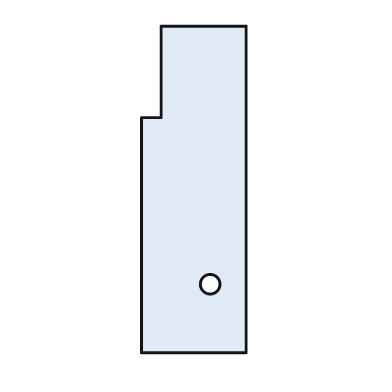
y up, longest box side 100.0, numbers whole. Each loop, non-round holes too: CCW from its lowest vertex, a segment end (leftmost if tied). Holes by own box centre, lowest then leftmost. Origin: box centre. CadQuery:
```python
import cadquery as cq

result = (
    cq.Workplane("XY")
    .moveTo(-16.0, -50.0)
    .lineTo(16.0, -50.0)
    .lineTo(16.0, 50.0)
    .lineTo(-10.0, 50.0)
    .lineTo(-10.0, 22.0)
    .lineTo(-16.0, 22.0)
    .close()
    .moveTo(5.0, -29.0)
    .circle(3.0)
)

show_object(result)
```